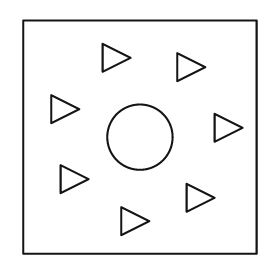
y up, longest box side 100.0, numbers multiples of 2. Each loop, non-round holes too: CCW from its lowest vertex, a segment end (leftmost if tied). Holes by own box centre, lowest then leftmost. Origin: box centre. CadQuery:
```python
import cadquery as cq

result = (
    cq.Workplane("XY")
    .moveTo(-50.0, -50.0)
    .lineTo(50.0, -50.0)
    .lineTo(50.0, 50.0)
    .lineTo(-50.0, 50.0)
    .close()
    .moveTo(-8.0, -42.0)
    .lineTo(4.0, -36.0)
    .lineTo(-8.0, -30.0)
    .close()
    .moveTo(20.0, -32.0)
    .lineTo(32.0, -26.0)
    .lineTo(20.0, -20.0)
    .close()
    .moveTo(-34.0, -24.0)
    .lineTo(-22.0, -18.0)
    .lineTo(-34.0, -12.0)
    .close()
    .moveTo(0.0, 0.0)
    .circle(14.0)
    .moveTo(32.0, -2.0)
    .lineTo(44.0, 4.0)
    .lineTo(32.0, 10.0)
    .close()
    .moveTo(-38.0, 6.0)
    .lineTo(-26.0, 12.0)
    .lineTo(-38.0, 18.0)
    .close()
    .moveTo(16.0, 24.0)
    .lineTo(28.0, 30.0)
    .lineTo(16.0, 36.0)
    .close()
    .moveTo(-16.0, 28.0)
    .lineTo(-4.0, 34.0)
    .lineTo(-16.0, 40.0)
    .close()
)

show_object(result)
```